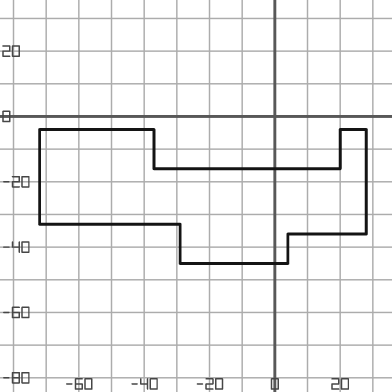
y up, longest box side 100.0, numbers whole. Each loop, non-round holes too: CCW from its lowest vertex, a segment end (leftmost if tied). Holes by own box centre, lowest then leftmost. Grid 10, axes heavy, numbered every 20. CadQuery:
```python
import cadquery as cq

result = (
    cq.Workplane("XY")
    .moveTo(-29.0, -45.0)
    .lineTo(4.0, -45.0)
    .lineTo(4.0, -36.0)
    .lineTo(28.0, -36.0)
    .lineTo(28.0, -4.0)
    .lineTo(20.0, -4.0)
    .lineTo(20.0, -16.0)
    .lineTo(-37.0, -16.0)
    .lineTo(-37.0, -4.0)
    .lineTo(-72.0, -4.0)
    .lineTo(-72.0, -33.0)
    .lineTo(-29.0, -33.0)
    .close()
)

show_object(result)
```